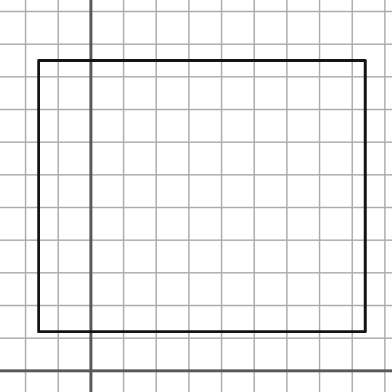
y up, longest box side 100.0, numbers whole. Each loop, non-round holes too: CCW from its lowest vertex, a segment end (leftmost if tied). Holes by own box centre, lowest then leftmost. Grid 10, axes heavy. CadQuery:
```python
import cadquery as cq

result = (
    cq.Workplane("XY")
    .moveTo(-16.0, 12.0)
    .lineTo(84.0, 12.0)
    .lineTo(84.0, 95.0)
    .lineTo(-16.0, 95.0)
    .close()
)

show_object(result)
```